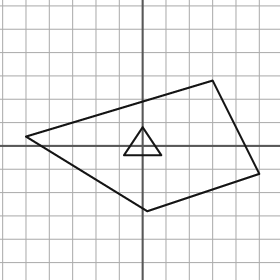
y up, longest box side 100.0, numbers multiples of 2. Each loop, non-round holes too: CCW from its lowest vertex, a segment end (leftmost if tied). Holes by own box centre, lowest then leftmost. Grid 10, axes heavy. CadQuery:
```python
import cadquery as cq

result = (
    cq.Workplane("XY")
    .moveTo(2.0, -28.0)
    .lineTo(50.0, -12.0)
    .lineTo(30.0, 28.0)
    .lineTo(-50.0, 4.0)
    .close()
    .moveTo(-8.0, -4.0)
    .lineTo(8.0, -4.0)
    .lineTo(0.0, 8.0)
    .close()
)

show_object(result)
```